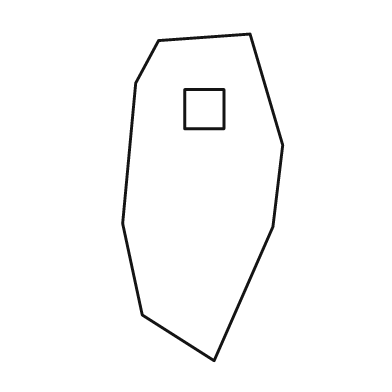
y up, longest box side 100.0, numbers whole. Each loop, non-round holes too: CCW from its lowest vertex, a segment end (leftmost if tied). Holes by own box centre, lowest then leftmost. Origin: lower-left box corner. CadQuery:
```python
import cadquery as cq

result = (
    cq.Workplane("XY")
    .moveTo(28.0, 0.0)
    .lineTo(46.0, 41.0)
    .lineTo(49.0, 66.0)
    .lineTo(39.0, 100.0)
    .lineTo(11.0, 98.0)
    .lineTo(4.0, 85.0)
    .lineTo(0.0, 42.0)
    .lineTo(6.0, 14.0)
    .close()
    .moveTo(19.0, 71.0)
    .lineTo(31.0, 71.0)
    .lineTo(31.0, 83.0)
    .lineTo(19.0, 83.0)
    .close()
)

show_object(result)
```